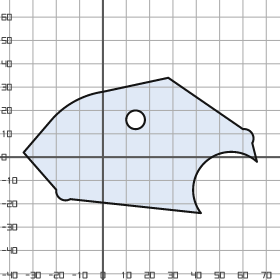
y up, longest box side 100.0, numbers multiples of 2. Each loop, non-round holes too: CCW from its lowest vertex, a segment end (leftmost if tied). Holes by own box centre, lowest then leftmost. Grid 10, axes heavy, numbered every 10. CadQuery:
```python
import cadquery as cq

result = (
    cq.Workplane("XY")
    .moveTo(42.0, -24.0)
    .threePointArc((44.0, -2.0), (66.0, -2.0))
    .lineTo(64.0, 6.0)
    .threePointArc((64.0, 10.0), (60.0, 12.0))
    .lineTo(28.0, 34.0)
    .lineTo(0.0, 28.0)
    .threePointArc((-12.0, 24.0), (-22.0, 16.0))
    .lineTo(-34.0, 2.0)
    .lineTo(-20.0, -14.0)
    .threePointArc((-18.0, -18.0), (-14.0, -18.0))
    .close()
    .moveTo(14.0, 16.0)
    .circle(4.0)
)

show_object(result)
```